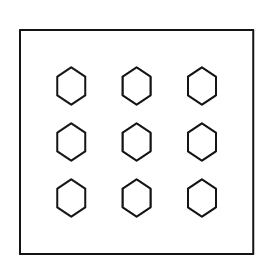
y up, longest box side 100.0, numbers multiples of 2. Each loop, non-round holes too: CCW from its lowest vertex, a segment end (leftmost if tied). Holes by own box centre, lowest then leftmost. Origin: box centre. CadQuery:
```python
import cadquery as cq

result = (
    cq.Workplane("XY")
    .moveTo(-50.0, -48.0)
    .lineTo(50.0, -48.0)
    .lineTo(50.0, 48.0)
    .lineTo(-50.0, 48.0)
    .close()
    .moveTo(-28.0, -32.0)
    .lineTo(-22.0, -28.0)
    .lineTo(-22.0, -20.0)
    .lineTo(-28.0, -16.0)
    .lineTo(-34.0, -20.0)
    .lineTo(-34.0, -28.0)
    .close()
    .moveTo(0.0, -32.0)
    .lineTo(6.0, -28.0)
    .lineTo(6.0, -20.0)
    .lineTo(0.0, -16.0)
    .lineTo(-6.0, -20.0)
    .lineTo(-6.0, -28.0)
    .close()
    .moveTo(28.0, -32.0)
    .lineTo(34.0, -28.0)
    .lineTo(34.0, -20.0)
    .lineTo(28.0, -16.0)
    .lineTo(22.0, -20.0)
    .lineTo(22.0, -28.0)
    .close()
    .moveTo(-28.0, -8.0)
    .lineTo(-22.0, -4.0)
    .lineTo(-22.0, 4.0)
    .lineTo(-28.0, 8.0)
    .lineTo(-34.0, 4.0)
    .lineTo(-34.0, -4.0)
    .close()
    .moveTo(0.0, -8.0)
    .lineTo(6.0, -4.0)
    .lineTo(6.0, 4.0)
    .lineTo(0.0, 8.0)
    .lineTo(-6.0, 4.0)
    .lineTo(-6.0, -4.0)
    .close()
    .moveTo(28.0, -8.0)
    .lineTo(34.0, -4.0)
    .lineTo(34.0, 4.0)
    .lineTo(28.0, 8.0)
    .lineTo(22.0, 4.0)
    .lineTo(22.0, -4.0)
    .close()
    .moveTo(-28.0, 16.0)
    .lineTo(-22.0, 20.0)
    .lineTo(-22.0, 28.0)
    .lineTo(-28.0, 32.0)
    .lineTo(-34.0, 28.0)
    .lineTo(-34.0, 20.0)
    .close()
    .moveTo(0.0, 16.0)
    .lineTo(6.0, 20.0)
    .lineTo(6.0, 28.0)
    .lineTo(0.0, 32.0)
    .lineTo(-6.0, 28.0)
    .lineTo(-6.0, 20.0)
    .close()
    .moveTo(28.0, 16.0)
    .lineTo(34.0, 20.0)
    .lineTo(34.0, 28.0)
    .lineTo(28.0, 32.0)
    .lineTo(22.0, 28.0)
    .lineTo(22.0, 20.0)
    .close()
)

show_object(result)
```